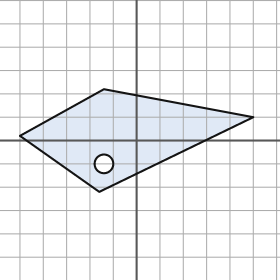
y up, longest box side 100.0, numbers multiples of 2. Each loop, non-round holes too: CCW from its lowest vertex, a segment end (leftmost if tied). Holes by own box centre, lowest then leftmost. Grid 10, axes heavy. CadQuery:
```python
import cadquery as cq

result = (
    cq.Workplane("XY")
    .moveTo(-16.0, -22.0)
    .lineTo(50.0, 10.0)
    .lineTo(-14.0, 22.0)
    .lineTo(-50.0, 2.0)
    .close()
    .moveTo(-14.0, -10.0)
    .circle(4.0)
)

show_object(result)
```